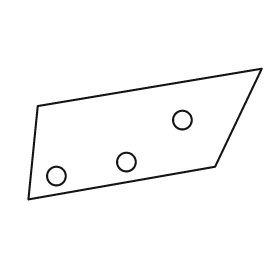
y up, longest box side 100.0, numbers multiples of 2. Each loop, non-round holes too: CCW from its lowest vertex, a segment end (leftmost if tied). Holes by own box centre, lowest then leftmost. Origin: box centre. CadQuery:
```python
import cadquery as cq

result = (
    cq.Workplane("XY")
    .moveTo(-50.0, -28.0)
    .lineTo(30.0, -14.0)
    .lineTo(50.0, 28.0)
    .lineTo(-46.0, 12.0)
    .close()
    .moveTo(-38.0, -18.0)
    .circle(4.0)
    .moveTo(-8.0, -12.0)
    .circle(4.0)
    .moveTo(16.0, 6.0)
    .circle(4.0)
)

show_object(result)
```